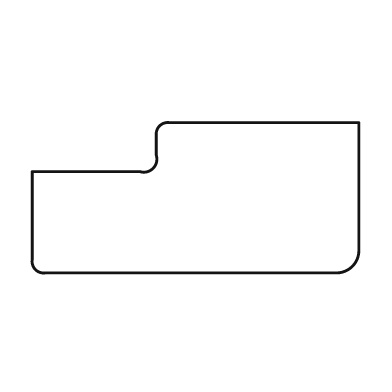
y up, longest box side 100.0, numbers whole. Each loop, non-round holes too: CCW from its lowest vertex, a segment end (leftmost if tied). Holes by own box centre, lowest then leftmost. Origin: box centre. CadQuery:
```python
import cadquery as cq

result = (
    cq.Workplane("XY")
    .moveTo(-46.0, -23.0)
    .lineTo(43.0, -23.0)
    .threePointArc((48.0, -21.0), (50.0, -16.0))
    .lineTo(50.0, 23.0)
    .lineTo(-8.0, 23.0)
    .threePointArc((-11.0, 22.0), (-12.0, 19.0))
    .lineTo(-12.0, 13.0)
    .threePointArc((-13.0, 9.0), (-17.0, 8.0))
    .lineTo(-50.0, 8.0)
    .lineTo(-50.0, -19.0)
    .threePointArc((-49.0, -22.0), (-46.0, -23.0))
    .close()
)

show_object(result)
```